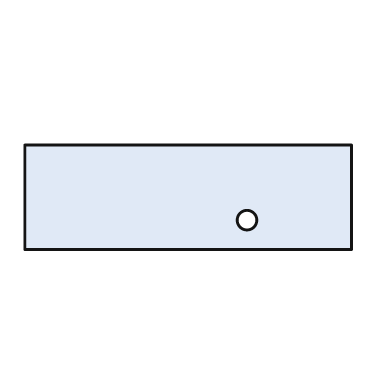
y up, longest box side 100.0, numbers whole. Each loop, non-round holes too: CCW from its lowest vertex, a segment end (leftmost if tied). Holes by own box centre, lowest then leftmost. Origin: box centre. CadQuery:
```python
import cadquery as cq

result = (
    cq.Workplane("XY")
    .moveTo(-50.0, -16.0)
    .lineTo(50.0, -16.0)
    .lineTo(50.0, 16.0)
    .lineTo(-50.0, 16.0)
    .close()
    .moveTo(18.0, -7.0)
    .circle(3.0)
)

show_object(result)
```